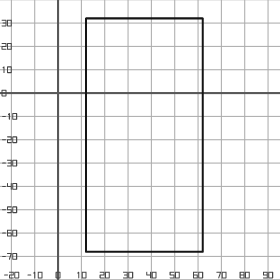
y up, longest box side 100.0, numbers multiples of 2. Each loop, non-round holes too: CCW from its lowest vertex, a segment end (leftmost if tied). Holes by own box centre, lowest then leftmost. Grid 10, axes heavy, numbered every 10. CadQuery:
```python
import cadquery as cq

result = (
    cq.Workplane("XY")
    .moveTo(12.0, -68.0)
    .lineTo(62.0, -68.0)
    .lineTo(62.0, 32.0)
    .lineTo(12.0, 32.0)
    .close()
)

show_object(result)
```